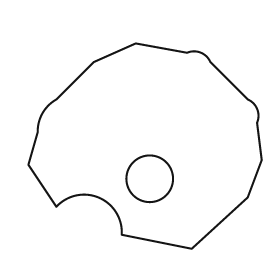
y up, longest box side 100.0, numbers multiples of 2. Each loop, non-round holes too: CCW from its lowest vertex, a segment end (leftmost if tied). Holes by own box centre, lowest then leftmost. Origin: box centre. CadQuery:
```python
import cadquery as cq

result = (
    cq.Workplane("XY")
    .moveTo(20.0, -44.0)
    .lineTo(44.0, -22.0)
    .lineTo(50.0, -6.0)
    .lineTo(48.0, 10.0)
    .threePointArc((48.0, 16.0), (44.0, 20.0))
    .lineTo(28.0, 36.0)
    .threePointArc((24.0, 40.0), (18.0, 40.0))
    .lineTo(-4.0, 44.0)
    .lineTo(-22.0, 36.0)
    .lineTo(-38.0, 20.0)
    .threePointArc((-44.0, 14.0), (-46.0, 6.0))
    .lineTo(-50.0, -8.0)
    .lineTo(-38.0, -26.0)
    .threePointArc((-20.0, -22.0), (-10.0, -38.0))
    .close()
    .moveTo(2.0, -14.0)
    .circle(10.0)
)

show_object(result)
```